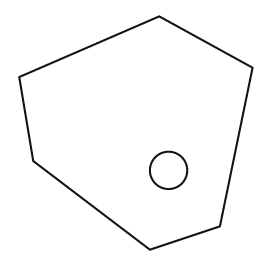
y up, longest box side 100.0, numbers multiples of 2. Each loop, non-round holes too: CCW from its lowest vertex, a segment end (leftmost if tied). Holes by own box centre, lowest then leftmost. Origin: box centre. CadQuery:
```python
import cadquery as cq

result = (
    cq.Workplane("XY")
    .moveTo(6.0, -50.0)
    .lineTo(36.0, -40.0)
    .lineTo(50.0, 28.0)
    .lineTo(10.0, 50.0)
    .lineTo(-50.0, 24.0)
    .lineTo(-44.0, -12.0)
    .close()
    .moveTo(14.0, -16.0)
    .circle(8.0)
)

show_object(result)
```